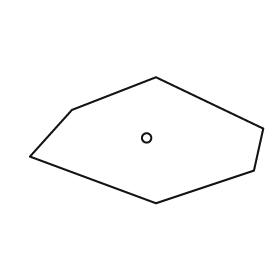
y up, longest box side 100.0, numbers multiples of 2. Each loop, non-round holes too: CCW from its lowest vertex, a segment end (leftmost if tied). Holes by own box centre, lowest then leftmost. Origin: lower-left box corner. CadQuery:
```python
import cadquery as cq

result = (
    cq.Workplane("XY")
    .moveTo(54.0, 0.0)
    .lineTo(96.0, 14.0)
    .lineTo(100.0, 32.0)
    .lineTo(54.0, 54.0)
    .lineTo(18.0, 40.0)
    .lineTo(0.0, 20.0)
    .close()
    .moveTo(50.0, 28.0)
    .circle(2.0)
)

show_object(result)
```